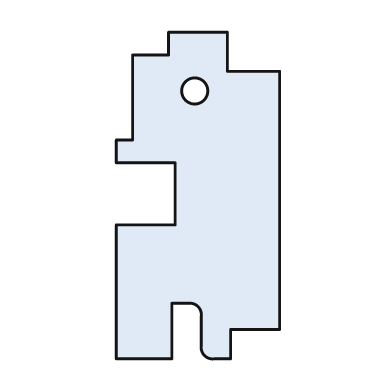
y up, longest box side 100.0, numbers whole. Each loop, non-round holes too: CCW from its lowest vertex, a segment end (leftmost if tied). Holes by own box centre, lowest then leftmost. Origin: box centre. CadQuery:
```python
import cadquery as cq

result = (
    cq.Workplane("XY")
    .moveTo(-25.0, -50.0)
    .lineTo(-8.0, -50.0)
    .lineTo(-8.0, -33.0)
    .lineTo(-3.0, -33.0)
    .threePointArc((0.0, -34.0), (1.0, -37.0))
    .lineTo(1.0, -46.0)
    .threePointArc((2.0, -49.0), (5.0, -50.0))
    .lineTo(10.0, -50.0)
    .lineTo(10.0, -41.0)
    .lineTo(25.0, -41.0)
    .lineTo(25.0, 38.0)
    .lineTo(9.0, 38.0)
    .lineTo(9.0, 50.0)
    .lineTo(-9.0, 50.0)
    .lineTo(-9.0, 43.0)
    .lineTo(-20.0, 43.0)
    .lineTo(-20.0, 17.0)
    .lineTo(-25.0, 17.0)
    .lineTo(-25.0, 10.0)
    .lineTo(-7.0, 10.0)
    .lineTo(-7.0, -9.0)
    .lineTo(-25.0, -9.0)
    .close()
    .moveTo(-1.0, 32.0)
    .circle(4.0)
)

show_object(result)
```